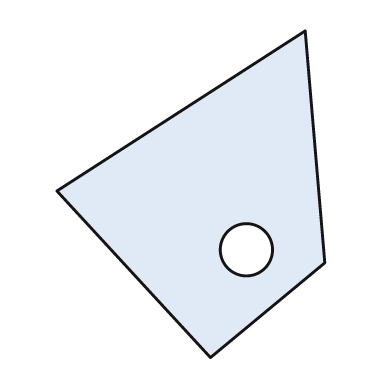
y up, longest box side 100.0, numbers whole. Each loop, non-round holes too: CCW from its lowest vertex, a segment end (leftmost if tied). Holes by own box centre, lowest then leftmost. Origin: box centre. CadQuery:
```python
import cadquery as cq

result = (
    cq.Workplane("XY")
    .moveTo(6.0, -50.0)
    .lineTo(41.0, -21.0)
    .lineTo(35.0, 50.0)
    .lineTo(-41.0, 1.0)
    .close()
    .moveTo(17.0, -17.0)
    .circle(8.0)
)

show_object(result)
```